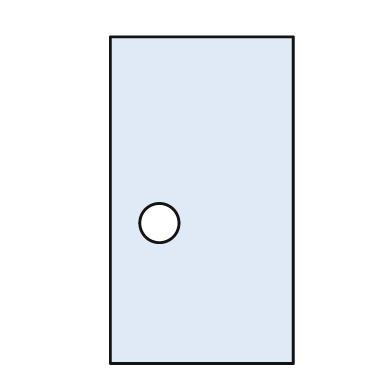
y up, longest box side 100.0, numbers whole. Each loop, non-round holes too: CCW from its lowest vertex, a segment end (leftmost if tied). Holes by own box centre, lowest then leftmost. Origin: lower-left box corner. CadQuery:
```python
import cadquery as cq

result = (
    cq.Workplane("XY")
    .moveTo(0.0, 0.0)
    .lineTo(56.0, 0.0)
    .lineTo(56.0, 100.0)
    .lineTo(0.0, 100.0)
    .close()
    .moveTo(15.0, 43.0)
    .circle(6.0)
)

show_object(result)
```